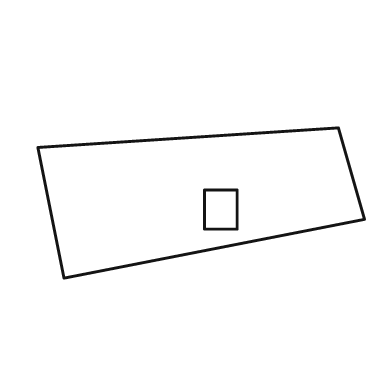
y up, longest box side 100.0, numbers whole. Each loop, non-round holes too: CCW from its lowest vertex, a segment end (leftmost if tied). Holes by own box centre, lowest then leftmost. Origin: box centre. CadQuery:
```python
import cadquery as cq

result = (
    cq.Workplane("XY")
    .moveTo(-42.0, -23.0)
    .lineTo(50.0, -5.0)
    .lineTo(42.0, 23.0)
    .lineTo(-50.0, 17.0)
    .close()
    .moveTo(1.0, -8.0)
    .lineTo(11.0, -8.0)
    .lineTo(11.0, 4.0)
    .lineTo(1.0, 4.0)
    .close()
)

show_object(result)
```